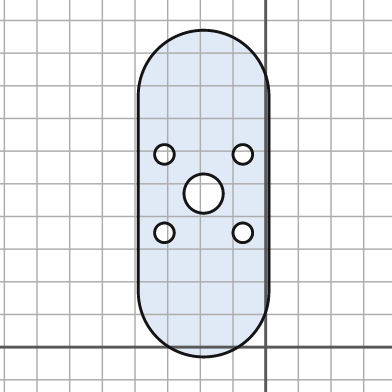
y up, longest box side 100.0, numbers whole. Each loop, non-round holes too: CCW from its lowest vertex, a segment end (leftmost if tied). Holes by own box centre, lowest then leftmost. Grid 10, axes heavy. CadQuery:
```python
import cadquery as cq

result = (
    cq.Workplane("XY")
    .moveTo(-39.0, 17.0)
    .threePointArc((-19.0, -3.0), (1.0, 17.0))
    .lineTo(1.0, 77.0)
    .threePointArc((-19.0, 97.0), (-39.0, 77.0))
    .close()
    .moveTo(-31.0, 35.0)
    .circle(3.0)
    .moveTo(-7.0, 35.0)
    .circle(3.0)
    .moveTo(-19.0, 47.0)
    .circle(6.0)
    .moveTo(-31.0, 59.0)
    .circle(3.0)
    .moveTo(-7.0, 59.0)
    .circle(3.0)
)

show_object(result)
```